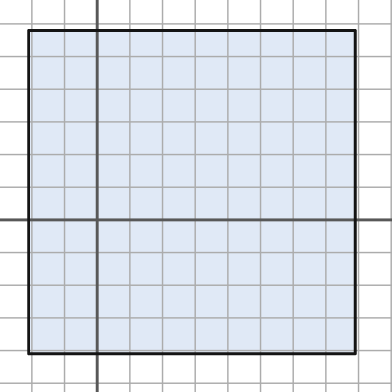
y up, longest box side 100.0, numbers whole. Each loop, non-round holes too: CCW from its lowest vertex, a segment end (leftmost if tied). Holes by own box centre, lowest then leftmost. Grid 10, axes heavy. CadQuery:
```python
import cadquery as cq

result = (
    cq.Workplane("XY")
    .moveTo(-21.0, -41.0)
    .lineTo(79.0, -41.0)
    .lineTo(79.0, 58.0)
    .lineTo(-21.0, 58.0)
    .close()
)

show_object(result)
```